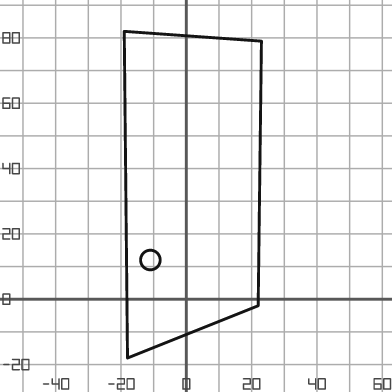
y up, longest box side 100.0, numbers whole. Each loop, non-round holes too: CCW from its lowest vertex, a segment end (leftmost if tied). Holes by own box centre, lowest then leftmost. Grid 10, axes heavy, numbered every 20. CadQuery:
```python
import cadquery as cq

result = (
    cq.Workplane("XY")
    .moveTo(-18.0, -18.0)
    .lineTo(22.0, -2.0)
    .lineTo(23.0, 79.0)
    .lineTo(-19.0, 82.0)
    .close()
    .moveTo(-11.0, 12.0)
    .circle(3.0)
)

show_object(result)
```